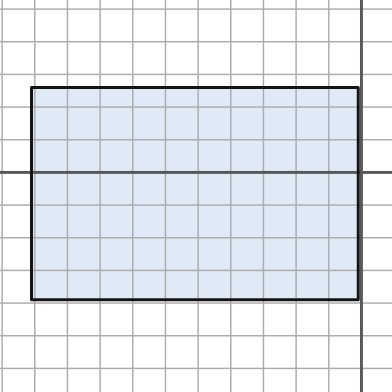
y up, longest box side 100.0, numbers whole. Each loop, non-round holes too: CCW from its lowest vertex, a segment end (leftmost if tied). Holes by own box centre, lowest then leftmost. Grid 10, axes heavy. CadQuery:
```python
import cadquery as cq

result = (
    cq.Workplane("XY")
    .moveTo(-101.0, -39.0)
    .lineTo(-1.0, -39.0)
    .lineTo(-1.0, 26.0)
    .lineTo(-101.0, 26.0)
    .close()
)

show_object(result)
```